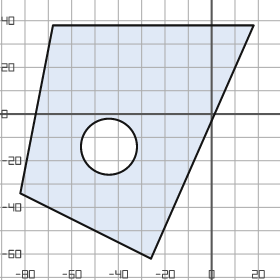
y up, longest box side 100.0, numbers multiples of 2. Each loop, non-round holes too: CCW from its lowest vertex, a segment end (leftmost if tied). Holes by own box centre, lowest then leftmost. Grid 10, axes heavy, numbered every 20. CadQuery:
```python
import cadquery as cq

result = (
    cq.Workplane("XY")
    .moveTo(-26.0, -62.0)
    .lineTo(18.0, 38.0)
    .lineTo(-68.0, 38.0)
    .lineTo(-82.0, -34.0)
    .close()
    .moveTo(-44.0, -14.0)
    .circle(12.0)
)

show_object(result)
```